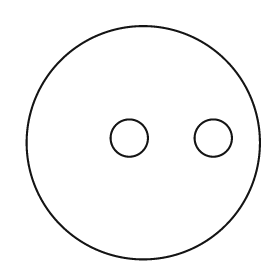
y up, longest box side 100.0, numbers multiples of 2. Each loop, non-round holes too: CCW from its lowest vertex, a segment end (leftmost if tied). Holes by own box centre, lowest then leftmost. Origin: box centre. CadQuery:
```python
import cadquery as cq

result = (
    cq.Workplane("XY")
    .moveTo(0.0, 0.0)
    .circle(50.0)
    .moveTo(-6.0, 2.0)
    .circle(8.0)
    .moveTo(30.0, 2.0)
    .circle(8.0)
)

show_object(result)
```